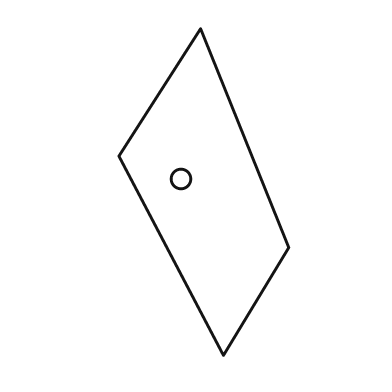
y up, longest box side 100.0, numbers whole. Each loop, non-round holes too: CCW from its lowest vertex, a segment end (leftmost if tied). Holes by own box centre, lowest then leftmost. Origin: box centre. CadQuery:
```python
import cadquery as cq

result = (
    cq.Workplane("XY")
    .moveTo(6.0, -50.0)
    .lineTo(26.0, -17.0)
    .lineTo(-1.0, 50.0)
    .lineTo(-26.0, 11.0)
    .close()
    .moveTo(-7.0, 4.0)
    .circle(3.0)
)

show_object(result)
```